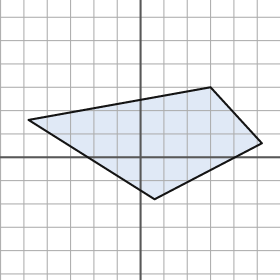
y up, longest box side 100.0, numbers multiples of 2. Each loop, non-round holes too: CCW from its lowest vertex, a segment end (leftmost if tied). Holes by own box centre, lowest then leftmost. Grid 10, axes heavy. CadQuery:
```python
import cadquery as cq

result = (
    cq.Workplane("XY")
    .moveTo(6.0, -18.0)
    .lineTo(52.0, 6.0)
    .lineTo(30.0, 30.0)
    .lineTo(-48.0, 16.0)
    .close()
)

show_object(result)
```